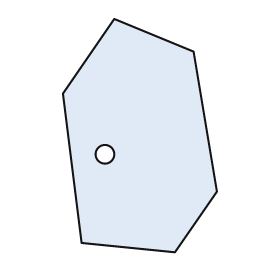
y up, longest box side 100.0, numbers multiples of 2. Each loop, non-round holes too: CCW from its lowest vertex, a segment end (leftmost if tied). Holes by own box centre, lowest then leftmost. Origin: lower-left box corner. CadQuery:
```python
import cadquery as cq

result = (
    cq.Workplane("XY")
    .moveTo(48.0, 0.0)
    .lineTo(66.0, 26.0)
    .lineTo(56.0, 86.0)
    .lineTo(22.0, 100.0)
    .lineTo(0.0, 68.0)
    .lineTo(8.0, 4.0)
    .close()
    .moveTo(18.0, 42.0)
    .circle(4.0)
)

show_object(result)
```